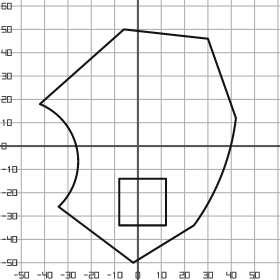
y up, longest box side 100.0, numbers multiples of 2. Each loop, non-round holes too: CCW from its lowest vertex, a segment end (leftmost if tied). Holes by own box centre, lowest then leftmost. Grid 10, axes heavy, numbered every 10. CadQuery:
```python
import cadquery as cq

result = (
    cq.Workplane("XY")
    .moveTo(-2.0, -50.0)
    .lineTo(24.0, -34.0)
    .threePointArc((36.0, -12.0), (42.0, 12.0))
    .lineTo(30.0, 46.0)
    .lineTo(-6.0, 50.0)
    .lineTo(-42.0, 18.0)
    .threePointArc((-26.0, -2.0), (-34.0, -26.0))
    .close()
    .moveTo(-8.0, -34.0)
    .lineTo(12.0, -34.0)
    .lineTo(12.0, -14.0)
    .lineTo(-8.0, -14.0)
    .close()
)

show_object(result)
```